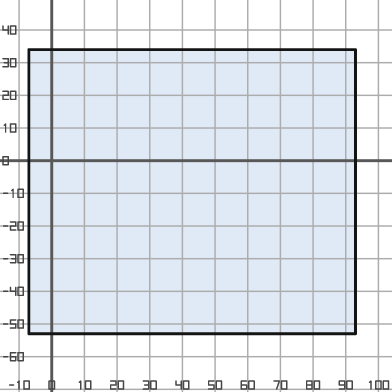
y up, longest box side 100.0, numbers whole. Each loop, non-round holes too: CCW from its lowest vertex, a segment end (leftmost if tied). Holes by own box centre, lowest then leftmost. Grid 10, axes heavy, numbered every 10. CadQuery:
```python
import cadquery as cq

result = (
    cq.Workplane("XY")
    .moveTo(-7.0, -53.0)
    .lineTo(93.0, -53.0)
    .lineTo(93.0, 34.0)
    .lineTo(-7.0, 34.0)
    .close()
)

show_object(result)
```